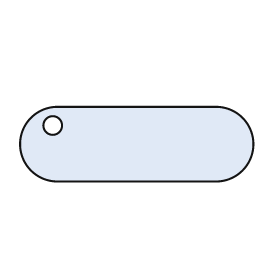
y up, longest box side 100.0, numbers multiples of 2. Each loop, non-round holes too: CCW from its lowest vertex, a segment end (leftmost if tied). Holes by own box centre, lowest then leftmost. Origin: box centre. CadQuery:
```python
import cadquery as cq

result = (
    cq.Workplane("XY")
    .moveTo(-34.0, -16.0)
    .lineTo(34.0, -16.0)
    .threePointArc((50.0, 0.0), (34.0, 16.0))
    .lineTo(-34.0, 16.0)
    .threePointArc((-50.0, 0.0), (-34.0, -16.0))
    .close()
    .moveTo(-36.0, 8.0)
    .circle(4.0)
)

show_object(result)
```